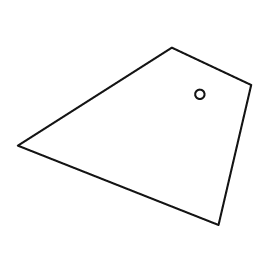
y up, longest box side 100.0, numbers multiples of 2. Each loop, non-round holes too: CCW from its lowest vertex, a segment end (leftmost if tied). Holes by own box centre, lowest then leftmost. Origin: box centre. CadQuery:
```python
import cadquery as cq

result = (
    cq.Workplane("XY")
    .moveTo(36.0, -38.0)
    .lineTo(50.0, 22.0)
    .lineTo(16.0, 38.0)
    .lineTo(-50.0, -4.0)
    .close()
    .moveTo(28.0, 18.0)
    .circle(2.0)
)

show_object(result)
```